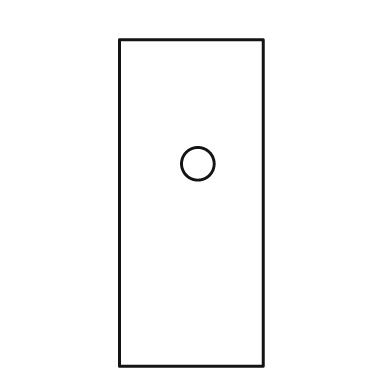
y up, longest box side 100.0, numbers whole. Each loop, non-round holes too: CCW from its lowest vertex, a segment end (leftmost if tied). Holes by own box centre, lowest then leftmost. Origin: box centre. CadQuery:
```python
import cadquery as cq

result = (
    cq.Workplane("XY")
    .moveTo(-22.0, -50.0)
    .lineTo(22.0, -50.0)
    .lineTo(22.0, 50.0)
    .lineTo(-22.0, 50.0)
    .close()
    .moveTo(2.0, 12.0)
    .circle(5.0)
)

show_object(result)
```